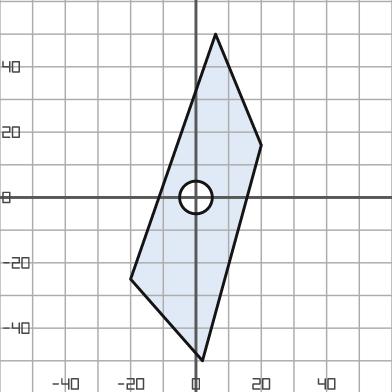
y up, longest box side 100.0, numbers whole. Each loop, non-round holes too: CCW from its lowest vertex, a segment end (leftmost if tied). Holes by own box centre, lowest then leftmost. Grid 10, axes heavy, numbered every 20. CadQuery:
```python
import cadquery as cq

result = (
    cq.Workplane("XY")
    .moveTo(2.0, -50.0)
    .lineTo(20.0, 16.0)
    .lineTo(6.0, 50.0)
    .lineTo(-20.0, -25.0)
    .close()
    .moveTo(0.0, 0.0)
    .circle(5.0)
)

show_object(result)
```